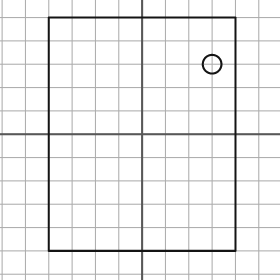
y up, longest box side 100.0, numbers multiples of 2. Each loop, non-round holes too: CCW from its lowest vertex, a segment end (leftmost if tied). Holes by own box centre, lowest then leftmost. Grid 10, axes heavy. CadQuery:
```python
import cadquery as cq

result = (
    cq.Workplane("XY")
    .moveTo(-40.0, -50.0)
    .lineTo(40.0, -50.0)
    .lineTo(40.0, 50.0)
    .lineTo(-40.0, 50.0)
    .close()
    .moveTo(30.0, 30.0)
    .circle(4.0)
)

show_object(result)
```